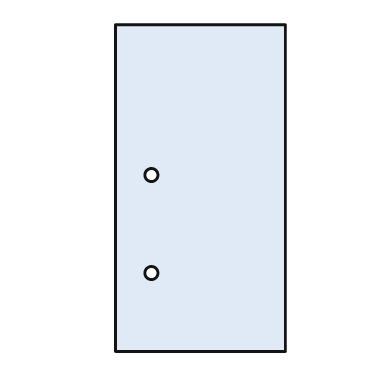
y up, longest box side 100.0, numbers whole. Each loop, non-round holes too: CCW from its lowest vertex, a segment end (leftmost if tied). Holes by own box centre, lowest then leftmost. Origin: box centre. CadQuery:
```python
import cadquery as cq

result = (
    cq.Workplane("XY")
    .moveTo(-26.0, -50.0)
    .lineTo(26.0, -50.0)
    .lineTo(26.0, 50.0)
    .lineTo(-26.0, 50.0)
    .close()
    .moveTo(-15.0, -26.0)
    .circle(2.0)
    .moveTo(-15.0, 4.0)
    .circle(2.0)
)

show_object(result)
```